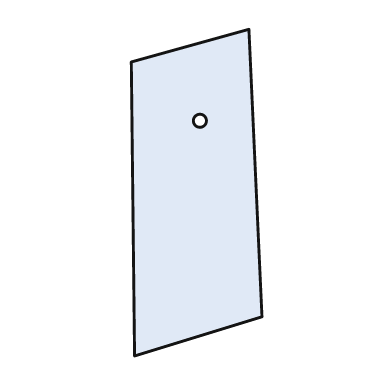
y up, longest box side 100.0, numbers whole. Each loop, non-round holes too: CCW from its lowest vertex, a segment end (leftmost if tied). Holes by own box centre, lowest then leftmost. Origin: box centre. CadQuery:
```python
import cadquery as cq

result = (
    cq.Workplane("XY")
    .moveTo(-19.0, -50.0)
    .lineTo(20.0, -38.0)
    .lineTo(16.0, 50.0)
    .lineTo(-20.0, 40.0)
    .close()
    .moveTo(1.0, 22.0)
    .circle(2.0)
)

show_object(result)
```